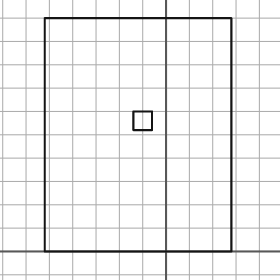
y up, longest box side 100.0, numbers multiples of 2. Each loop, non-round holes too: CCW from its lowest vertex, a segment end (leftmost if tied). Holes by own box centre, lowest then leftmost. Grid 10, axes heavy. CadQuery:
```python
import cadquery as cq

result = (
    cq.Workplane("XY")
    .moveTo(-52.0, 0.0)
    .lineTo(28.0, 0.0)
    .lineTo(28.0, 100.0)
    .lineTo(-52.0, 100.0)
    .close()
    .moveTo(-14.0, 52.0)
    .lineTo(-6.0, 52.0)
    .lineTo(-6.0, 60.0)
    .lineTo(-14.0, 60.0)
    .close()
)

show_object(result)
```